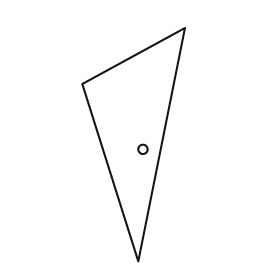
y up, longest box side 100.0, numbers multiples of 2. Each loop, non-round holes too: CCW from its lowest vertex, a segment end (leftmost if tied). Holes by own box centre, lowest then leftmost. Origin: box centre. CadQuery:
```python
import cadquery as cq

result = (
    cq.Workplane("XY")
    .moveTo(2.0, -50.0)
    .lineTo(22.0, 50.0)
    .lineTo(-22.0, 26.0)
    .close()
    .moveTo(4.0, -2.0)
    .circle(2.0)
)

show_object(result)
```